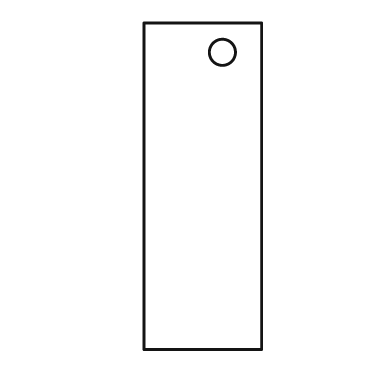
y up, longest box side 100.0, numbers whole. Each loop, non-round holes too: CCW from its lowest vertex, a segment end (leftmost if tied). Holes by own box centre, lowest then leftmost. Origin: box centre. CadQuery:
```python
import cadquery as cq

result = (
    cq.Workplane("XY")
    .moveTo(-18.0, -50.0)
    .lineTo(18.0, -50.0)
    .lineTo(18.0, 50.0)
    .lineTo(-18.0, 50.0)
    .close()
    .moveTo(6.0, 41.0)
    .circle(4.0)
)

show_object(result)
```